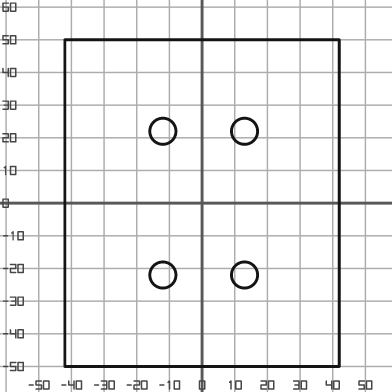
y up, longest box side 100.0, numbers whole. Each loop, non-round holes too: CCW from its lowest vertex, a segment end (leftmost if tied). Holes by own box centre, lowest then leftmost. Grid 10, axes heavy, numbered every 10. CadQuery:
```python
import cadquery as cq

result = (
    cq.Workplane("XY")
    .moveTo(-42.0, -50.0)
    .lineTo(42.0, -50.0)
    .lineTo(42.0, 50.0)
    .lineTo(-42.0, 50.0)
    .close()
    .moveTo(-12.0, -22.0)
    .circle(4.0)
    .moveTo(13.0, -22.0)
    .circle(4.0)
    .moveTo(-12.0, 22.0)
    .circle(4.0)
    .moveTo(13.0, 22.0)
    .circle(4.0)
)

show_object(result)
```